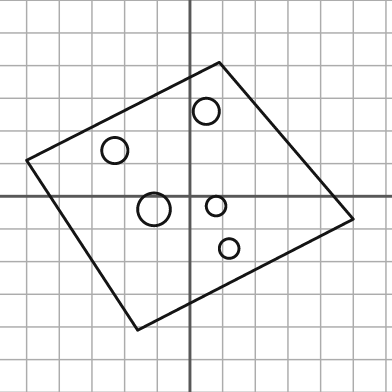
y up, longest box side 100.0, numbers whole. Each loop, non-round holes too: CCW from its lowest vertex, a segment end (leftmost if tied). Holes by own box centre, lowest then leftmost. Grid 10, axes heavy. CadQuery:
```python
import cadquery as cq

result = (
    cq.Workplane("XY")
    .moveTo(-16.0, -41.0)
    .lineTo(50.0, -7.0)
    .lineTo(9.0, 41.0)
    .lineTo(-50.0, 11.0)
    .close()
    .moveTo(12.0, -16.0)
    .circle(3.0)
    .moveTo(-11.0, -4.0)
    .circle(5.0)
    .moveTo(8.0, -3.0)
    .circle(3.0)
    .moveTo(-23.0, 14.0)
    .circle(4.0)
    .moveTo(5.0, 26.0)
    .circle(4.0)
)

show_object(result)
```